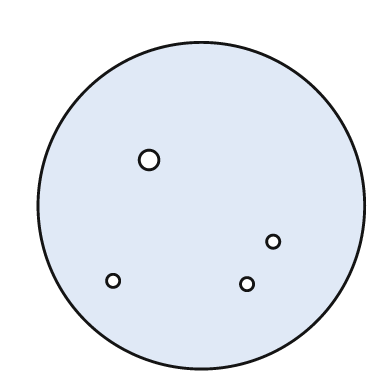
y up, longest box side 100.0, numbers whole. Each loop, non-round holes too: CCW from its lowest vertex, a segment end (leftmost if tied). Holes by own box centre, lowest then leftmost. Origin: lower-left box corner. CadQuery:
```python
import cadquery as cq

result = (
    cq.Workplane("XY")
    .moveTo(50.0, 50.0)
    .circle(50.0)
    .moveTo(64.0, 26.0)
    .circle(2.0)
    .moveTo(23.0, 27.0)
    .circle(2.0)
    .moveTo(72.0, 39.0)
    .circle(2.0)
    .moveTo(34.0, 64.0)
    .circle(3.0)
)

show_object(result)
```